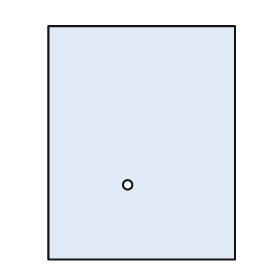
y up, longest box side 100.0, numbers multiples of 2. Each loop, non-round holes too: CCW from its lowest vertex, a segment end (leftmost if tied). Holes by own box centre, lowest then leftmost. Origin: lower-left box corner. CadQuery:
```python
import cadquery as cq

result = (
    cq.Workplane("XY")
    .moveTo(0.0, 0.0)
    .lineTo(80.0, 0.0)
    .lineTo(80.0, 100.0)
    .lineTo(0.0, 100.0)
    .close()
    .moveTo(34.0, 32.0)
    .circle(2.0)
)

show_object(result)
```